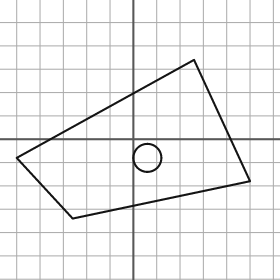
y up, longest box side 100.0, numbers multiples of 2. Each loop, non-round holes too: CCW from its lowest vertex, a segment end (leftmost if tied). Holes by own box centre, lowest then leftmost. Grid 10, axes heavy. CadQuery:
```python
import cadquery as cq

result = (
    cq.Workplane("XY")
    .moveTo(-26.0, -34.0)
    .lineTo(50.0, -18.0)
    .lineTo(26.0, 34.0)
    .lineTo(-50.0, -8.0)
    .close()
    .moveTo(6.0, -8.0)
    .circle(6.0)
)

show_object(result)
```